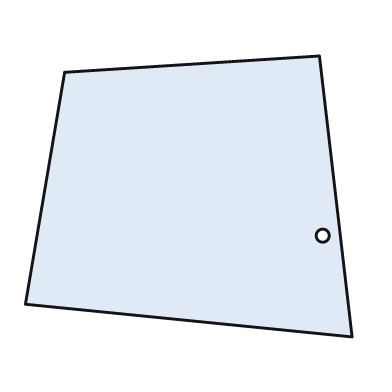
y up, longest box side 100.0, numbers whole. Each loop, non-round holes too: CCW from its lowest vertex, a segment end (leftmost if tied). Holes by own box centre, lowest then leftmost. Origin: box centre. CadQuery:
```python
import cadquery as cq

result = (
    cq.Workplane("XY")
    .moveTo(50.0, -43.0)
    .lineTo(40.0, 43.0)
    .lineTo(-38.0, 38.0)
    .lineTo(-50.0, -33.0)
    .close()
    .moveTo(41.0, -12.0)
    .circle(2.0)
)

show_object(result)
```